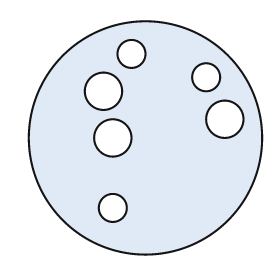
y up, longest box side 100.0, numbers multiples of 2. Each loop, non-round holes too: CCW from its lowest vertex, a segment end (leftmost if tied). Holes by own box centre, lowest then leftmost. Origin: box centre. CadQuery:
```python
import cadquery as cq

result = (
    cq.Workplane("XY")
    .moveTo(0.0, 0.0)
    .circle(50.0)
    .moveTo(-14.0, -30.0)
    .circle(6.0)
    .moveTo(-14.0, 0.0)
    .circle(8.0)
    .moveTo(34.0, 8.0)
    .circle(8.0)
    .moveTo(-18.0, 20.0)
    .circle(8.0)
    .moveTo(26.0, 26.0)
    .circle(6.0)
    .moveTo(-6.0, 36.0)
    .circle(6.0)
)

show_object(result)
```